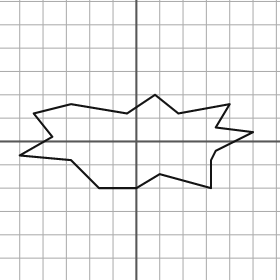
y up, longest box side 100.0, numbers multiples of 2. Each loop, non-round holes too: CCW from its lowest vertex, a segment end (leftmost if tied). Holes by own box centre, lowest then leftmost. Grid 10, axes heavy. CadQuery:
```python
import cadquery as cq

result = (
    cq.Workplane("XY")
    .moveTo(-16.0, -20.0)
    .lineTo(0.0, -20.0)
    .lineTo(10.0, -14.0)
    .lineTo(32.0, -20.0)
    .lineTo(32.0, -8.0)
    .lineTo(34.0, -4.0)
    .lineTo(50.0, 4.0)
    .lineTo(34.0, 6.0)
    .lineTo(40.0, 16.0)
    .lineTo(18.0, 12.0)
    .lineTo(8.0, 20.0)
    .lineTo(-4.0, 12.0)
    .lineTo(-28.0, 16.0)
    .lineTo(-44.0, 12.0)
    .lineTo(-36.0, 2.0)
    .lineTo(-50.0, -6.0)
    .lineTo(-28.0, -8.0)
    .close()
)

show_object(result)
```